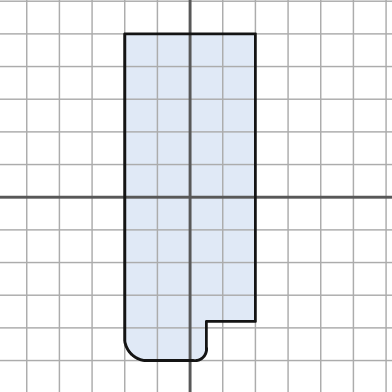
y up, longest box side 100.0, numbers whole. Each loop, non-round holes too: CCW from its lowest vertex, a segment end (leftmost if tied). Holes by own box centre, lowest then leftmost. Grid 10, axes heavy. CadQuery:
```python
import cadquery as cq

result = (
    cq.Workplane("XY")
    .moveTo(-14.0, -50.0)
    .lineTo(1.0, -50.0)
    .threePointArc((4.0, -49.0), (5.0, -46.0))
    .lineTo(5.0, -38.0)
    .lineTo(20.0, -38.0)
    .lineTo(20.0, 50.0)
    .lineTo(-20.0, 50.0)
    .lineTo(-20.0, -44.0)
    .threePointArc((-18.0, -48.0), (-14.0, -50.0))
    .close()
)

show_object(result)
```